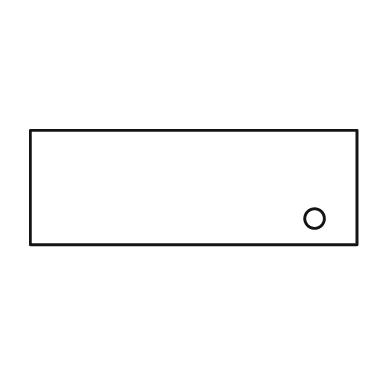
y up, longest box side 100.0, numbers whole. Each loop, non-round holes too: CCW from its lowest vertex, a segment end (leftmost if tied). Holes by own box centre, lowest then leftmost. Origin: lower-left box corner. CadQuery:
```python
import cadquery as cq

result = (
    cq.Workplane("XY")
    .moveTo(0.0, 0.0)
    .lineTo(100.0, 0.0)
    .lineTo(100.0, 35.0)
    .lineTo(0.0, 35.0)
    .close()
    .moveTo(87.0, 8.0)
    .circle(3.0)
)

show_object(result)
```